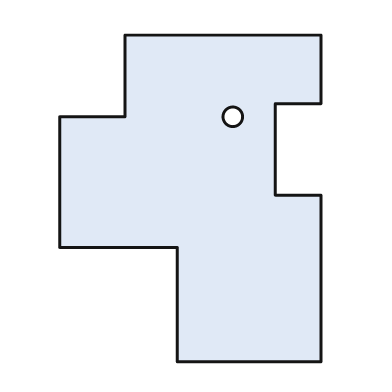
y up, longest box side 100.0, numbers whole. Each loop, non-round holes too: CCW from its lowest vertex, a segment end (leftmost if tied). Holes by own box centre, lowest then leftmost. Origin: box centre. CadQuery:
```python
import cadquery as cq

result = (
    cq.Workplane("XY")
    .moveTo(-4.0, -50.0)
    .lineTo(40.0, -50.0)
    .lineTo(40.0, 1.0)
    .lineTo(26.0, 1.0)
    .lineTo(26.0, 29.0)
    .lineTo(40.0, 29.0)
    .lineTo(40.0, 50.0)
    .lineTo(-20.0, 50.0)
    .lineTo(-20.0, 25.0)
    .lineTo(-40.0, 25.0)
    .lineTo(-40.0, -15.0)
    .lineTo(-4.0, -15.0)
    .close()
    .moveTo(13.0, 25.0)
    .circle(3.0)
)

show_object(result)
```